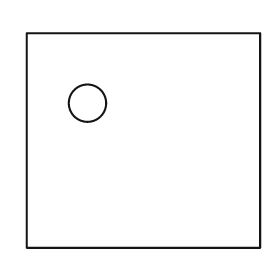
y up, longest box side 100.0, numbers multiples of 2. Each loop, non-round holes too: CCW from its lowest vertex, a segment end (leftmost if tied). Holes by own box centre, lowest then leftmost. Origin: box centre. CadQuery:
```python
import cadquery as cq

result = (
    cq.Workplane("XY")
    .moveTo(-50.0, -46.0)
    .lineTo(50.0, -46.0)
    .lineTo(50.0, 46.0)
    .lineTo(-50.0, 46.0)
    .close()
    .moveTo(-24.0, 16.0)
    .circle(8.0)
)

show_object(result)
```